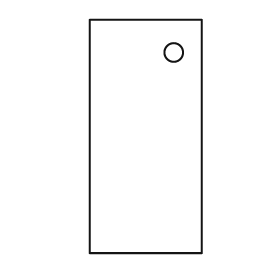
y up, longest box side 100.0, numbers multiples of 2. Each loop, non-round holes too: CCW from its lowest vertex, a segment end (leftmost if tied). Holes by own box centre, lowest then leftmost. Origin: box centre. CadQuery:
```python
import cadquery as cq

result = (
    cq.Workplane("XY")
    .moveTo(-24.0, -50.0)
    .lineTo(24.0, -50.0)
    .lineTo(24.0, 50.0)
    .lineTo(-24.0, 50.0)
    .close()
    .moveTo(12.0, 36.0)
    .circle(4.0)
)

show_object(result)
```